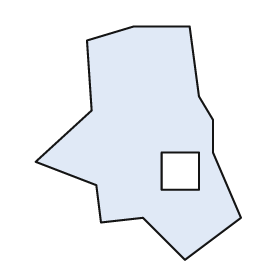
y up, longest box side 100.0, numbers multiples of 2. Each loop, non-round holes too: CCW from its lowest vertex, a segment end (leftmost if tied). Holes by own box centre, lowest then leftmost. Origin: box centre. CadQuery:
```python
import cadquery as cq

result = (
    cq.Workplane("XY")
    .moveTo(20.0, -50.0)
    .lineTo(44.0, -32.0)
    .lineTo(32.0, -4.0)
    .lineTo(32.0, 10.0)
    .lineTo(26.0, 20.0)
    .lineTo(22.0, 50.0)
    .lineTo(-2.0, 50.0)
    .lineTo(-22.0, 44.0)
    .lineTo(-20.0, 14.0)
    .lineTo(-44.0, -8.0)
    .lineTo(-18.0, -18.0)
    .lineTo(-16.0, -34.0)
    .lineTo(2.0, -32.0)
    .close()
    .moveTo(10.0, -20.0)
    .lineTo(26.0, -20.0)
    .lineTo(26.0, -4.0)
    .lineTo(10.0, -4.0)
    .close()
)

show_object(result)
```